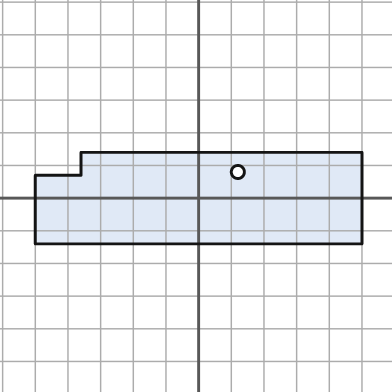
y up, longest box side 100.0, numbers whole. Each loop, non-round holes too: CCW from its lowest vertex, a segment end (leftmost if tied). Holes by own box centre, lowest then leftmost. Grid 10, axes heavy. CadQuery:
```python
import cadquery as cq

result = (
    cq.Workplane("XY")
    .moveTo(-50.0, -14.0)
    .lineTo(50.0, -14.0)
    .lineTo(50.0, 14.0)
    .lineTo(-36.0, 14.0)
    .lineTo(-36.0, 7.0)
    .lineTo(-50.0, 7.0)
    .close()
    .moveTo(12.0, 8.0)
    .circle(2.0)
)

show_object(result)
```